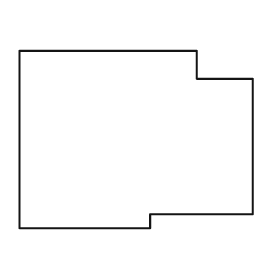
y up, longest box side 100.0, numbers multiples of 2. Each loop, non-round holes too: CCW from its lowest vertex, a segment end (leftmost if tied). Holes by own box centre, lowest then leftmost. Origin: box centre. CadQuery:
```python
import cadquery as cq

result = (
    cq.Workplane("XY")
    .moveTo(-50.0, -38.0)
    .lineTo(6.0, -38.0)
    .lineTo(6.0, -32.0)
    .lineTo(50.0, -32.0)
    .lineTo(50.0, 26.0)
    .lineTo(26.0, 26.0)
    .lineTo(26.0, 38.0)
    .lineTo(-50.0, 38.0)
    .close()
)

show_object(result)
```